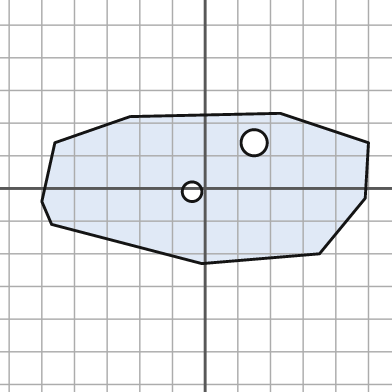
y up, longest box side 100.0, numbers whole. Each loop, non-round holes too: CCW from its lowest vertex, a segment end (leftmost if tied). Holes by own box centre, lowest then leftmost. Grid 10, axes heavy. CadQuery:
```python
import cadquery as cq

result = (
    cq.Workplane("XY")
    .moveTo(-1.0, -23.0)
    .lineTo(35.0, -20.0)
    .lineTo(49.0, -3.0)
    .lineTo(50.0, 14.0)
    .lineTo(23.0, 23.0)
    .lineTo(-23.0, 22.0)
    .lineTo(-46.0, 14.0)
    .lineTo(-50.0, -4.0)
    .lineTo(-47.0, -11.0)
    .close()
    .moveTo(-4.0, -1.0)
    .circle(3.0)
    .moveTo(15.0, 14.0)
    .circle(4.0)
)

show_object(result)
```